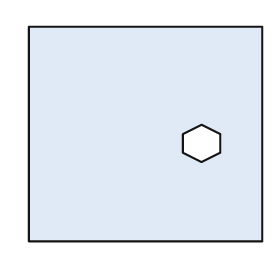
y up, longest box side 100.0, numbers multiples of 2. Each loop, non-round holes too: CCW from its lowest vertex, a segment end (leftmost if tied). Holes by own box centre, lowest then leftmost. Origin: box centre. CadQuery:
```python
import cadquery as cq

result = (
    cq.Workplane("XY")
    .moveTo(-50.0, -46.0)
    .lineTo(50.0, -46.0)
    .lineTo(50.0, 46.0)
    .lineTo(-50.0, 46.0)
    .close()
    .moveTo(24.0, -12.0)
    .lineTo(32.0, -8.0)
    .lineTo(32.0, 0.0)
    .lineTo(24.0, 4.0)
    .lineTo(16.0, 0.0)
    .lineTo(16.0, -8.0)
    .close()
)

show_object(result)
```